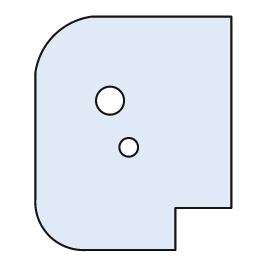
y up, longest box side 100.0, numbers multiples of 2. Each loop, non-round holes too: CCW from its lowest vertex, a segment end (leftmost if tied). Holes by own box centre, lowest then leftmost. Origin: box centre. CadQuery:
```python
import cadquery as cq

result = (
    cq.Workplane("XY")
    .moveTo(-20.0, -50.0)
    .lineTo(18.0, -50.0)
    .lineTo(18.0, -32.0)
    .lineTo(42.0, -32.0)
    .lineTo(42.0, 50.0)
    .lineTo(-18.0, 50.0)
    .threePointArc((-34.0, 42.0), (-42.0, 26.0))
    .lineTo(-42.0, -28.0)
    .threePointArc((-36.0, -44.0), (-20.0, -50.0))
    .close()
    .moveTo(-2.0, -6.0)
    .circle(4.0)
    .moveTo(-10.0, 14.0)
    .circle(6.0)
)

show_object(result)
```